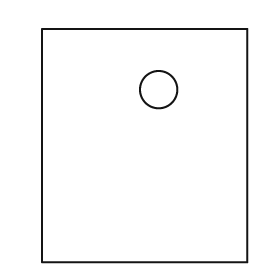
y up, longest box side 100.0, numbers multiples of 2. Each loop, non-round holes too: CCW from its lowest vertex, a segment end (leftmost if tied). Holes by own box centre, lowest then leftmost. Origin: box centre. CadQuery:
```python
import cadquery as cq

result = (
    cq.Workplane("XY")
    .moveTo(-44.0, -50.0)
    .lineTo(44.0, -50.0)
    .lineTo(44.0, 50.0)
    .lineTo(-44.0, 50.0)
    .close()
    .moveTo(6.0, 24.0)
    .circle(8.0)
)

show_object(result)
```